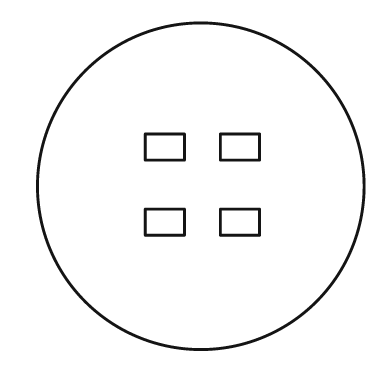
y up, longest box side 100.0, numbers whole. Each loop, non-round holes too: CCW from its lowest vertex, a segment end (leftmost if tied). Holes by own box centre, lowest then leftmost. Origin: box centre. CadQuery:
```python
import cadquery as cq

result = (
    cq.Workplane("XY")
    .moveTo(0.0, 0.0)
    .circle(50.0)
    .moveTo(-17.0, -15.0)
    .lineTo(-5.0, -15.0)
    .lineTo(-5.0, -7.0)
    .lineTo(-17.0, -7.0)
    .close()
    .moveTo(6.0, -15.0)
    .lineTo(18.0, -15.0)
    .lineTo(18.0, -7.0)
    .lineTo(6.0, -7.0)
    .close()
    .moveTo(-17.0, 8.0)
    .lineTo(-5.0, 8.0)
    .lineTo(-5.0, 16.0)
    .lineTo(-17.0, 16.0)
    .close()
    .moveTo(6.0, 8.0)
    .lineTo(18.0, 8.0)
    .lineTo(18.0, 16.0)
    .lineTo(6.0, 16.0)
    .close()
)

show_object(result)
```